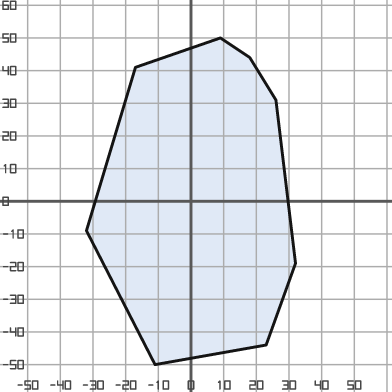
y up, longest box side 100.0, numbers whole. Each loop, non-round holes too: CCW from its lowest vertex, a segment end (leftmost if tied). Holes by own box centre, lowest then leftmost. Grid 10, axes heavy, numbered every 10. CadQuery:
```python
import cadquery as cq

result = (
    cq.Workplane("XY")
    .moveTo(-11.0, -50.0)
    .lineTo(23.0, -44.0)
    .lineTo(32.0, -19.0)
    .lineTo(26.0, 31.0)
    .lineTo(18.0, 44.0)
    .lineTo(9.0, 50.0)
    .lineTo(-17.0, 41.0)
    .lineTo(-32.0, -9.0)
    .close()
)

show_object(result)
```